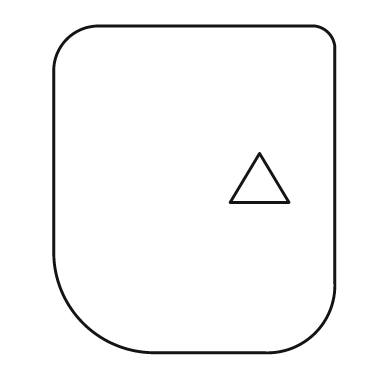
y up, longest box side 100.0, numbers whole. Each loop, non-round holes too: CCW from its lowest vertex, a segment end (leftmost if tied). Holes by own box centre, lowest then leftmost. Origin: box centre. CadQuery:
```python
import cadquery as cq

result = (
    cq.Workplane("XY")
    .moveTo(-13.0, -50.0)
    .lineTo(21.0, -50.0)
    .threePointArc((37.0, -44.0), (43.0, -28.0))
    .lineTo(43.0, 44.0)
    .threePointArc((41.0, 48.0), (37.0, 50.0))
    .lineTo(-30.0, 50.0)
    .threePointArc((-39.0, 46.0), (-43.0, 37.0))
    .lineTo(-43.0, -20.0)
    .threePointArc((-34.0, -41.0), (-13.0, -50.0))
    .close()
    .moveTo(11.0, -4.0)
    .lineTo(29.0, -4.0)
    .lineTo(20.0, 11.0)
    .close()
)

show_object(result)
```